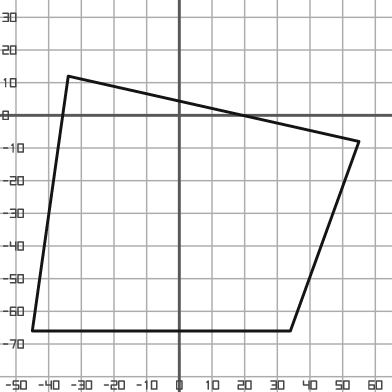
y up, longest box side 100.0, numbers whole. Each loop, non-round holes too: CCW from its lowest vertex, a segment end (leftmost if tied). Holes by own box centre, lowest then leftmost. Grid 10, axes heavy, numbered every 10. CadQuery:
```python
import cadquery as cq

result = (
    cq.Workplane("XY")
    .moveTo(-45.0, -66.0)
    .lineTo(34.0, -66.0)
    .lineTo(55.0, -8.0)
    .lineTo(-34.0, 12.0)
    .close()
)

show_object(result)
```